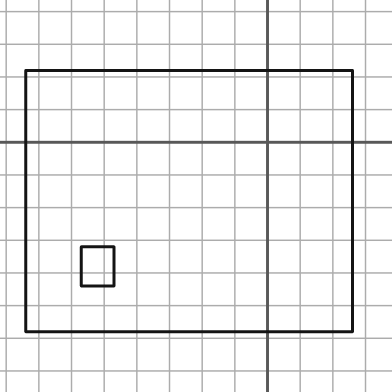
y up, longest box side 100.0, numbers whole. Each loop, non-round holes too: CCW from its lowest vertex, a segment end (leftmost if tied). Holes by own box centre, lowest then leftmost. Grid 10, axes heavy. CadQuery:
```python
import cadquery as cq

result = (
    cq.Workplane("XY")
    .moveTo(-74.0, -58.0)
    .lineTo(26.0, -58.0)
    .lineTo(26.0, 22.0)
    .lineTo(-74.0, 22.0)
    .close()
    .moveTo(-57.0, -44.0)
    .lineTo(-47.0, -44.0)
    .lineTo(-47.0, -32.0)
    .lineTo(-57.0, -32.0)
    .close()
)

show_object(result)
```